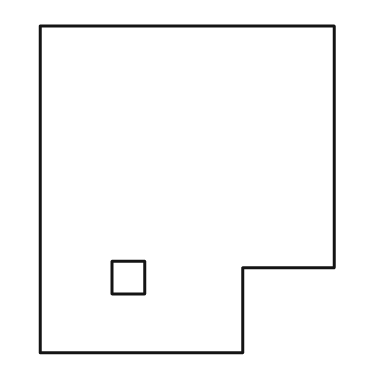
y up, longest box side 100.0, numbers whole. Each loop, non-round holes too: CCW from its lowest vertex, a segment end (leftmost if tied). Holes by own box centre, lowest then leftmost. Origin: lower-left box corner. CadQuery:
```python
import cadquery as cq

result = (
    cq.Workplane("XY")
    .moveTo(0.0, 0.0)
    .lineTo(62.0, 0.0)
    .lineTo(62.0, 26.0)
    .lineTo(90.0, 26.0)
    .lineTo(90.0, 100.0)
    .lineTo(0.0, 100.0)
    .close()
    .moveTo(22.0, 18.0)
    .lineTo(32.0, 18.0)
    .lineTo(32.0, 28.0)
    .lineTo(22.0, 28.0)
    .close()
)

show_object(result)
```